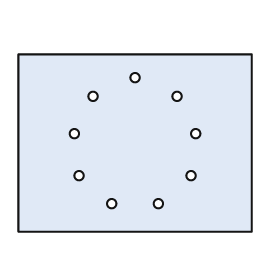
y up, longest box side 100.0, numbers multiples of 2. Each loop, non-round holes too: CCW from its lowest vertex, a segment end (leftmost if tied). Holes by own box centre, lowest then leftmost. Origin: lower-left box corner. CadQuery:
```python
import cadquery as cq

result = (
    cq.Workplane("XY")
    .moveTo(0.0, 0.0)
    .lineTo(100.0, 0.0)
    .lineTo(100.0, 76.0)
    .lineTo(0.0, 76.0)
    .close()
    .moveTo(40.0, 12.0)
    .circle(2.0)
    .moveTo(60.0, 12.0)
    .circle(2.0)
    .moveTo(26.0, 24.0)
    .circle(2.0)
    .moveTo(74.0, 24.0)
    .circle(2.0)
    .moveTo(24.0, 42.0)
    .circle(2.0)
    .moveTo(76.0, 42.0)
    .circle(2.0)
    .moveTo(32.0, 58.0)
    .circle(2.0)
    .moveTo(68.0, 58.0)
    .circle(2.0)
    .moveTo(50.0, 66.0)
    .circle(2.0)
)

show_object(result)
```